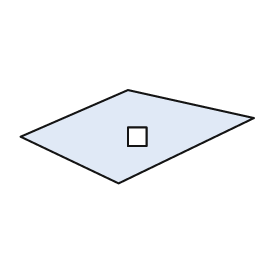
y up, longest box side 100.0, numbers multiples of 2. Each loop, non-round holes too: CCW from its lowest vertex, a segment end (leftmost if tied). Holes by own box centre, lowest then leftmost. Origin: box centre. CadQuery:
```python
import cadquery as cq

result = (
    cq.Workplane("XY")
    .moveTo(-8.0, -20.0)
    .lineTo(50.0, 8.0)
    .lineTo(-4.0, 20.0)
    .lineTo(-50.0, 0.0)
    .close()
    .moveTo(-4.0, -4.0)
    .lineTo(4.0, -4.0)
    .lineTo(4.0, 4.0)
    .lineTo(-4.0, 4.0)
    .close()
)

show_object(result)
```